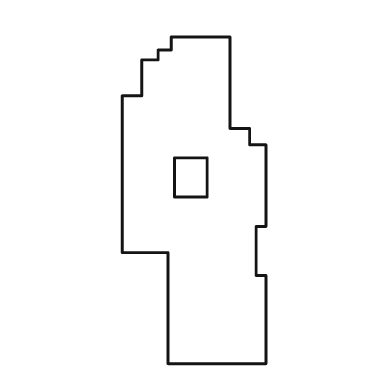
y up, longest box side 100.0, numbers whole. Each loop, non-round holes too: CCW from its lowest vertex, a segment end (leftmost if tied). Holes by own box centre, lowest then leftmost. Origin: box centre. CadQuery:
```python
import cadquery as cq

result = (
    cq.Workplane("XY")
    .moveTo(-8.0, -50.0)
    .lineTo(22.0, -50.0)
    .lineTo(22.0, -23.0)
    .lineTo(19.0, -23.0)
    .lineTo(19.0, -8.0)
    .lineTo(22.0, -8.0)
    .lineTo(22.0, 17.0)
    .lineTo(17.0, 17.0)
    .lineTo(17.0, 22.0)
    .lineTo(11.0, 22.0)
    .lineTo(11.0, 50.0)
    .lineTo(-7.0, 50.0)
    .lineTo(-7.0, 46.0)
    .lineTo(-11.0, 46.0)
    .lineTo(-11.0, 43.0)
    .lineTo(-16.0, 43.0)
    .lineTo(-16.0, 32.0)
    .lineTo(-22.0, 32.0)
    .lineTo(-22.0, -16.0)
    .lineTo(-8.0, -16.0)
    .close()
    .moveTo(-6.0, 1.0)
    .lineTo(4.0, 1.0)
    .lineTo(4.0, 13.0)
    .lineTo(-6.0, 13.0)
    .close()
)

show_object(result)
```